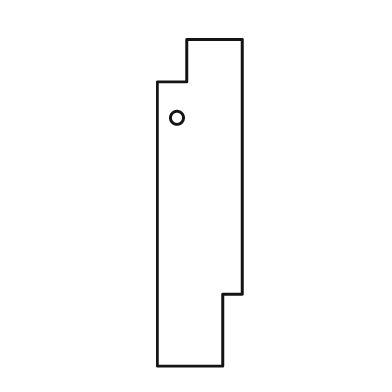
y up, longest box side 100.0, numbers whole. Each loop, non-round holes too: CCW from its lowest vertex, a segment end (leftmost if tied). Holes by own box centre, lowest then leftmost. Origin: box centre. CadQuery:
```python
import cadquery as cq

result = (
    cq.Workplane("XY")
    .moveTo(-13.0, -50.0)
    .lineTo(7.0, -50.0)
    .lineTo(7.0, -28.0)
    .lineTo(13.0, -28.0)
    .lineTo(13.0, 50.0)
    .lineTo(-4.0, 50.0)
    .lineTo(-4.0, 37.0)
    .lineTo(-13.0, 37.0)
    .close()
    .moveTo(-7.0, 26.0)
    .circle(2.0)
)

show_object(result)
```